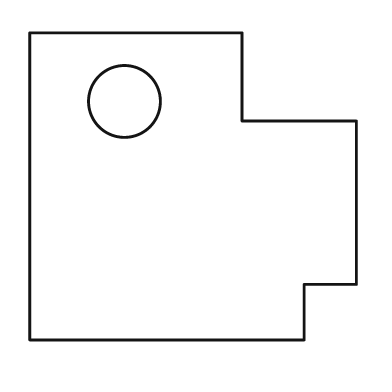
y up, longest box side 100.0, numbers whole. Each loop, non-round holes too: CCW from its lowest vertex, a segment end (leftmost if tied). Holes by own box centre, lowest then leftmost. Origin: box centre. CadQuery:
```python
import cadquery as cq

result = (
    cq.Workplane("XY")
    .moveTo(-50.0, -47.0)
    .lineTo(34.0, -47.0)
    .lineTo(34.0, -30.0)
    .lineTo(50.0, -30.0)
    .lineTo(50.0, 20.0)
    .lineTo(15.0, 20.0)
    .lineTo(15.0, 47.0)
    .lineTo(-50.0, 47.0)
    .close()
    .moveTo(-21.0, 26.0)
    .circle(11.0)
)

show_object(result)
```